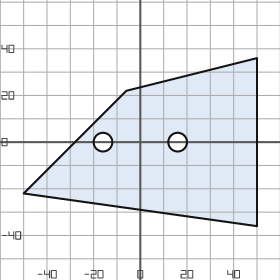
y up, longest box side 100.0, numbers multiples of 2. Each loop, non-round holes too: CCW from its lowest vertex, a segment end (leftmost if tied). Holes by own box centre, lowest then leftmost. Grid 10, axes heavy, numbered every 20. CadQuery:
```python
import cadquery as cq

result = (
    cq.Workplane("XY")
    .moveTo(50.0, -36.0)
    .lineTo(50.0, 36.0)
    .lineTo(-6.0, 22.0)
    .lineTo(-50.0, -22.0)
    .close()
    .moveTo(-16.0, 0.0)
    .circle(4.0)
    .moveTo(16.0, 0.0)
    .circle(4.0)
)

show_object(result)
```